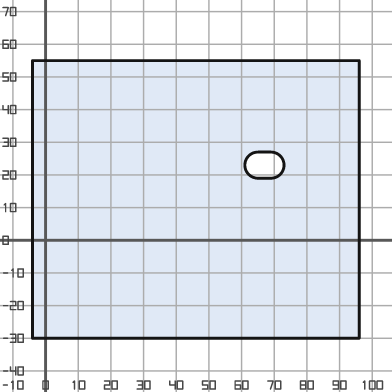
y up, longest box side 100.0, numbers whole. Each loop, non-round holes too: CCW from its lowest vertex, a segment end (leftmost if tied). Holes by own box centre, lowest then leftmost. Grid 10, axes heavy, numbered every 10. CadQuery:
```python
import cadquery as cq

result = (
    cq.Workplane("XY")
    .moveTo(-4.0, -30.0)
    .lineTo(96.0, -30.0)
    .lineTo(96.0, 55.0)
    .lineTo(-4.0, 55.0)
    .close()
    .moveTo(65.0, 19.0)
    .lineTo(69.0, 19.0)
    .threePointArc((73.0, 23.0), (69.0, 27.0))
    .lineTo(65.0, 27.0)
    .threePointArc((61.0, 23.0), (65.0, 19.0))
    .close()
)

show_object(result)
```